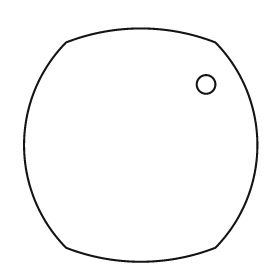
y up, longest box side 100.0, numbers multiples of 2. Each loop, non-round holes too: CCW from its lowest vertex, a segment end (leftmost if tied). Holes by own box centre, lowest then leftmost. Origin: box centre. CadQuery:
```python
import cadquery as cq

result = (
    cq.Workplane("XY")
    .moveTo(-32.0, -44.0)
    .threePointArc((0.0, -50.0), (32.0, -44.0))
    .threePointArc((50.0, 0.0), (32.0, 44.0))
    .threePointArc((0.0, 50.0), (-32.0, 44.0))
    .threePointArc((-50.0, 0.0), (-32.0, -44.0))
    .close()
    .moveTo(28.0, 26.0)
    .circle(4.0)
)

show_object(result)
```